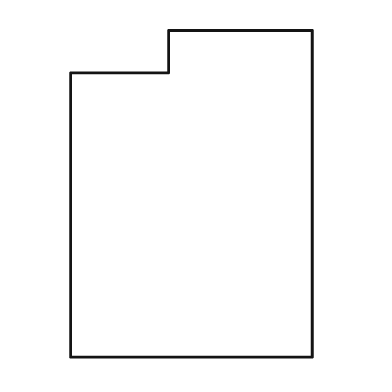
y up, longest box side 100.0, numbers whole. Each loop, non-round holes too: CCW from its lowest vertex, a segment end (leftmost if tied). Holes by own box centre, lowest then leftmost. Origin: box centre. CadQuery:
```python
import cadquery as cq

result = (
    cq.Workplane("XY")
    .moveTo(-37.0, -50.0)
    .lineTo(37.0, -50.0)
    .lineTo(37.0, 50.0)
    .lineTo(-7.0, 50.0)
    .lineTo(-7.0, 37.0)
    .lineTo(-37.0, 37.0)
    .close()
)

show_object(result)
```